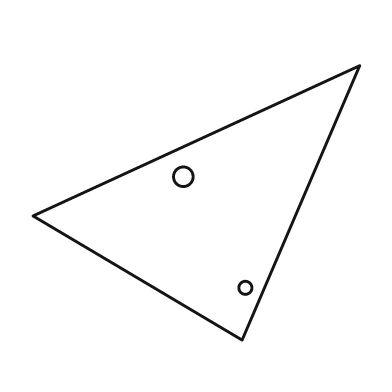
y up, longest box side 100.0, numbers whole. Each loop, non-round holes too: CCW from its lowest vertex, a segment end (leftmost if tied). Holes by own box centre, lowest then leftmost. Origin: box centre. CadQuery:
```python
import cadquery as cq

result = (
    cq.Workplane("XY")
    .moveTo(14.0, -42.0)
    .lineTo(50.0, 42.0)
    .lineTo(-50.0, -4.0)
    .close()
    .moveTo(15.0, -26.0)
    .circle(2.0)
    .moveTo(-4.0, 8.0)
    .circle(3.0)
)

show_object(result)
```